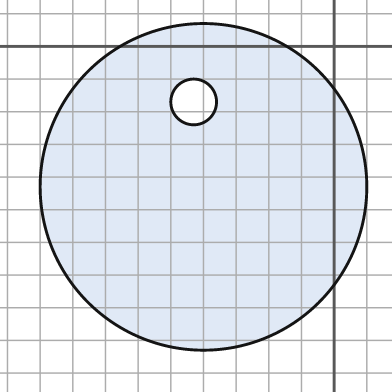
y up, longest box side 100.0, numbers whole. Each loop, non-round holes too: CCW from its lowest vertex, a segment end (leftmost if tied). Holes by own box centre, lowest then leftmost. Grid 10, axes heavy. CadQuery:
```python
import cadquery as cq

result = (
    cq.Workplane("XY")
    .moveTo(-40.0, -43.0)
    .circle(50.0)
    .moveTo(-43.0, -17.0)
    .circle(7.0)
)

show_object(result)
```